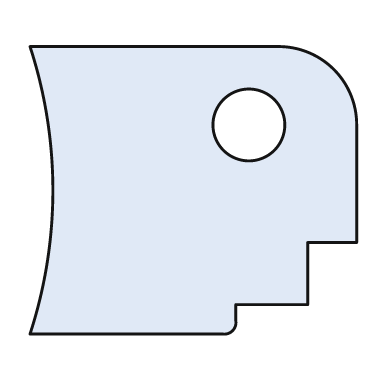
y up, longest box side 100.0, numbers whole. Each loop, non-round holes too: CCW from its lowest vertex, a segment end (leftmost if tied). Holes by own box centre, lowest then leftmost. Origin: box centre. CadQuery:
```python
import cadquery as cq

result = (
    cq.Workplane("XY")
    .moveTo(-50.0, -44.0)
    .lineTo(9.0, -44.0)
    .threePointArc((12.0, -43.0), (13.0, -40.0))
    .lineTo(13.0, -35.0)
    .lineTo(35.0, -35.0)
    .lineTo(35.0, -16.0)
    .lineTo(50.0, -16.0)
    .lineTo(50.0, 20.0)
    .threePointArc((43.0, 37.0), (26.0, 44.0))
    .lineTo(-50.0, 44.0)
    .threePointArc((-43.0, 0.0), (-50.0, -44.0))
    .close()
    .moveTo(17.0, 20.0)
    .circle(11.0)
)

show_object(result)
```